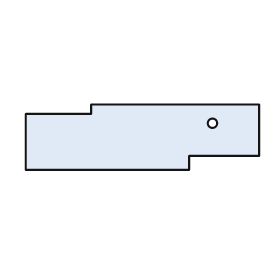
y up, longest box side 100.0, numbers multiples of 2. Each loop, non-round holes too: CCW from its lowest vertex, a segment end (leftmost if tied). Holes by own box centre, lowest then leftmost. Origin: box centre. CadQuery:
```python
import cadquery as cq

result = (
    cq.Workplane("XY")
    .moveTo(-50.0, -14.0)
    .lineTo(20.0, -14.0)
    .lineTo(20.0, -8.0)
    .lineTo(50.0, -8.0)
    .lineTo(50.0, 14.0)
    .lineTo(-22.0, 14.0)
    .lineTo(-22.0, 10.0)
    .lineTo(-50.0, 10.0)
    .close()
    .moveTo(30.0, 6.0)
    .circle(2.0)
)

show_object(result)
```